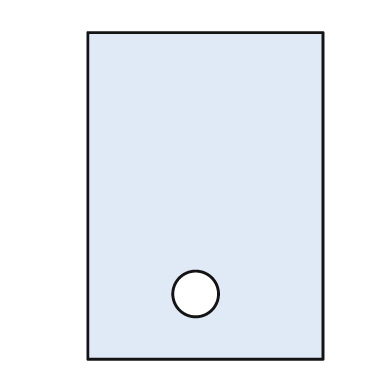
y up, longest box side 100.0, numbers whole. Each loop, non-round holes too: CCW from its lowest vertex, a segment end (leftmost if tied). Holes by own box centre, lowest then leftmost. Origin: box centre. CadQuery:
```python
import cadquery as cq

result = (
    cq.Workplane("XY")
    .moveTo(-36.0, -50.0)
    .lineTo(36.0, -50.0)
    .lineTo(36.0, 50.0)
    .lineTo(-36.0, 50.0)
    .close()
    .moveTo(-3.0, -30.0)
    .circle(7.0)
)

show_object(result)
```